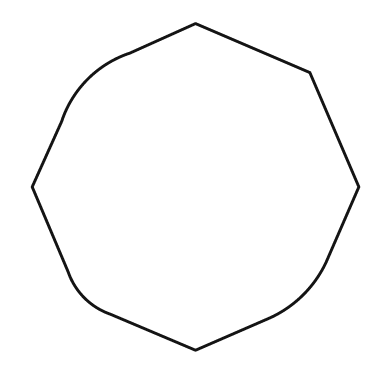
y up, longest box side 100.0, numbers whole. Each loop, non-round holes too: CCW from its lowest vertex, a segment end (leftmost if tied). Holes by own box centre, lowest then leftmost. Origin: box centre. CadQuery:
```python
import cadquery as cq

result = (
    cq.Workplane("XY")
    .moveTo(0.0, -50.0)
    .lineTo(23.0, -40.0)
    .threePointArc((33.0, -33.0), (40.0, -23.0))
    .lineTo(50.0, 0.0)
    .lineTo(35.0, 35.0)
    .lineTo(0.0, 50.0)
    .lineTo(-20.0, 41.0)
    .threePointArc((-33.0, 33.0), (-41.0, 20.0))
    .lineTo(-50.0, 0.0)
    .lineTo(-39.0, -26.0)
    .threePointArc((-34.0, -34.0), (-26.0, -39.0))
    .close()
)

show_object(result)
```